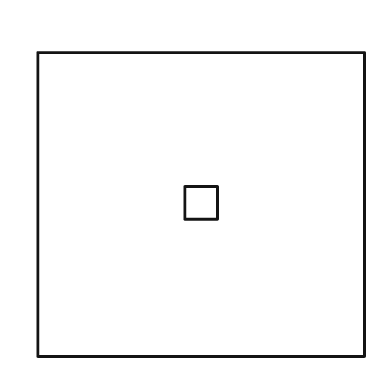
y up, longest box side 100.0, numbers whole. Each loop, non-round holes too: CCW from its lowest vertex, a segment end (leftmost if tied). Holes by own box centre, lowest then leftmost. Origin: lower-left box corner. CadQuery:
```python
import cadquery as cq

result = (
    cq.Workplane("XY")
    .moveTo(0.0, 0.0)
    .lineTo(100.0, 0.0)
    .lineTo(100.0, 93.0)
    .lineTo(0.0, 93.0)
    .close()
    .moveTo(45.0, 42.0)
    .lineTo(55.0, 42.0)
    .lineTo(55.0, 52.0)
    .lineTo(45.0, 52.0)
    .close()
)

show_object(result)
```